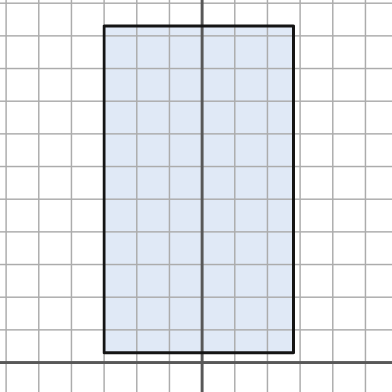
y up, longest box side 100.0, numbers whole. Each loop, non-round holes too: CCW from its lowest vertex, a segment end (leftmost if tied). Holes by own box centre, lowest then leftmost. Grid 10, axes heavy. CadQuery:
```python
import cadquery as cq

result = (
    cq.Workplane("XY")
    .moveTo(-30.0, 3.0)
    .lineTo(28.0, 3.0)
    .lineTo(28.0, 103.0)
    .lineTo(-30.0, 103.0)
    .close()
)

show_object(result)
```